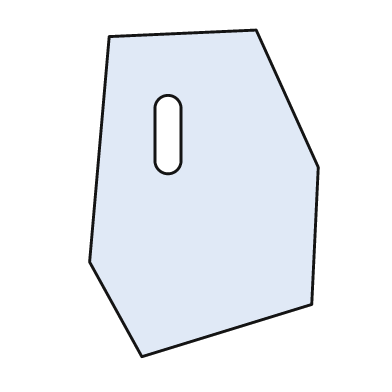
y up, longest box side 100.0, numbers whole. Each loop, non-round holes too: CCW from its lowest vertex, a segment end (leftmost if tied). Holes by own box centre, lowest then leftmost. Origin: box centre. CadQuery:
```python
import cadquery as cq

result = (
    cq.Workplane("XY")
    .moveTo(-19.0, -50.0)
    .lineTo(33.0, -34.0)
    .lineTo(35.0, 8.0)
    .lineTo(16.0, 50.0)
    .lineTo(-29.0, 48.0)
    .lineTo(-35.0, -21.0)
    .close()
    .moveTo(-15.0, 10.0)
    .threePointArc((-11.0, 6.0), (-7.0, 10.0))
    .lineTo(-7.0, 26.0)
    .threePointArc((-11.0, 30.0), (-15.0, 26.0))
    .close()
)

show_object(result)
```